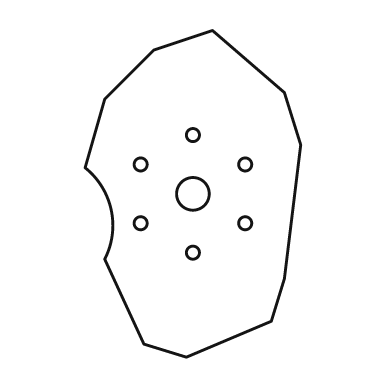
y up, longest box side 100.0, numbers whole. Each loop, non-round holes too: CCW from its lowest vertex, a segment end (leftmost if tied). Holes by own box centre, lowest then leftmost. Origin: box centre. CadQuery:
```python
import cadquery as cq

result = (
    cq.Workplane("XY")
    .moveTo(-2.0, -50.0)
    .lineTo(24.0, -39.0)
    .lineTo(28.0, -26.0)
    .lineTo(33.0, 15.0)
    .lineTo(28.0, 31.0)
    .lineTo(6.0, 50.0)
    .lineTo(-12.0, 44.0)
    .lineTo(-27.0, 29.0)
    .lineTo(-33.0, 8.0)
    .threePointArc((-25.0, -5.0), (-27.0, -20.0))
    .lineTo(-15.0, -46.0)
    .close()
    .moveTo(0.0, -18.0)
    .circle(2.0)
    .moveTo(-16.0, -9.0)
    .circle(2.0)
    .moveTo(16.0, -9.0)
    .circle(2.0)
    .moveTo(0.0, 0.0)
    .circle(5.0)
    .moveTo(-16.0, 9.0)
    .circle(2.0)
    .moveTo(16.0, 9.0)
    .circle(2.0)
    .moveTo(0.0, 18.0)
    .circle(2.0)
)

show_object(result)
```